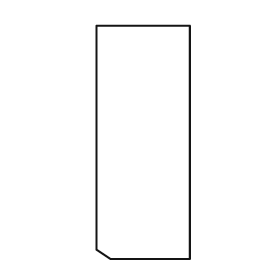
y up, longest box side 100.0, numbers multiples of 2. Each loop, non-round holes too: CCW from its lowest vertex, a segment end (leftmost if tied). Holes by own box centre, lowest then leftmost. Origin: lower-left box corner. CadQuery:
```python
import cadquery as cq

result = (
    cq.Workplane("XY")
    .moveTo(6.0, 0.0)
    .lineTo(40.0, 0.0)
    .lineTo(40.0, 100.0)
    .lineTo(0.0, 100.0)
    .lineTo(0.0, 4.0)
    .close()
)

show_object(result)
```